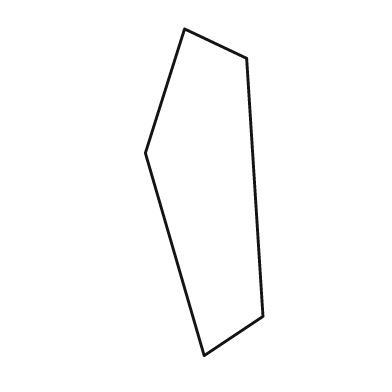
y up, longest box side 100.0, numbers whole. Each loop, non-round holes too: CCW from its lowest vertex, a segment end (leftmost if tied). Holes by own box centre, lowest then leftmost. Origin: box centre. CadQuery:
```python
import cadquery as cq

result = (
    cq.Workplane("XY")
    .moveTo(0.0, -50.0)
    .lineTo(18.0, -38.0)
    .lineTo(13.0, 41.0)
    .lineTo(-6.0, 50.0)
    .lineTo(-18.0, 12.0)
    .close()
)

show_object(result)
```